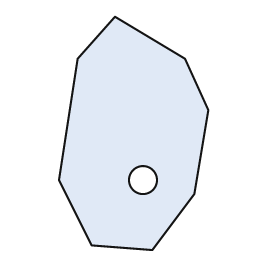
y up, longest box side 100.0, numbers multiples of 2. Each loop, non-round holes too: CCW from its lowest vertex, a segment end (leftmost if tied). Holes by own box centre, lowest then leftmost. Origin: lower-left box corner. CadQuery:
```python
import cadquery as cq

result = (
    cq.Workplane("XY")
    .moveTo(40.0, 0.0)
    .lineTo(58.0, 24.0)
    .lineTo(64.0, 60.0)
    .lineTo(54.0, 82.0)
    .lineTo(24.0, 100.0)
    .lineTo(8.0, 82.0)
    .lineTo(0.0, 30.0)
    .lineTo(14.0, 2.0)
    .close()
    .moveTo(36.0, 30.0)
    .circle(6.0)
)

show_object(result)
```